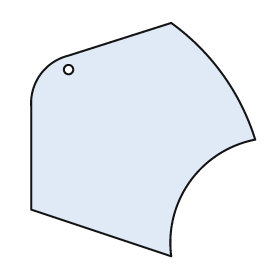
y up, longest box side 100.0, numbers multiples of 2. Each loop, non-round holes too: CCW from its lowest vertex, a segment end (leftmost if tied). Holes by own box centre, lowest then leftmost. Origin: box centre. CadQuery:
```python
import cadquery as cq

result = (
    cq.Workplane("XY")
    .moveTo(12.0, -50.0)
    .threePointArc((20.0, -18.0), (48.0, 0.0))
    .threePointArc((34.0, 28.0), (12.0, 50.0))
    .lineTo(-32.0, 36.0)
    .threePointArc((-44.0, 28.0), (-48.0, 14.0))
    .lineTo(-48.0, -30.0)
    .close()
    .moveTo(-32.0, 30.0)
    .circle(2.0)
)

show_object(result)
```